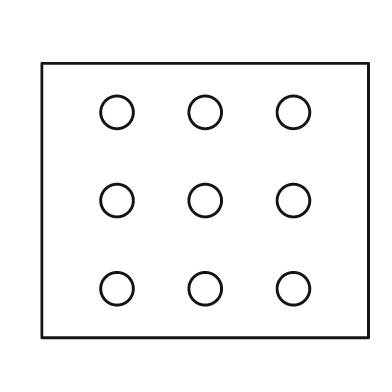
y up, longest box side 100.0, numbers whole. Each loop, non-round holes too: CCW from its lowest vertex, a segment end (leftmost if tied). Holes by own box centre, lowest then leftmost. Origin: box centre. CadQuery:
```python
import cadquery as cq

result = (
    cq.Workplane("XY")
    .moveTo(-50.0, -42.0)
    .lineTo(50.0, -42.0)
    .lineTo(50.0, 42.0)
    .lineTo(-50.0, 42.0)
    .close()
    .moveTo(-27.0, -27.0)
    .circle(5.0)
    .moveTo(0.0, -27.0)
    .circle(5.0)
    .moveTo(27.0, -27.0)
    .circle(5.0)
    .moveTo(-27.0, 0.0)
    .circle(5.0)
    .moveTo(0.0, 0.0)
    .circle(5.0)
    .moveTo(27.0, 0.0)
    .circle(5.0)
    .moveTo(-27.0, 27.0)
    .circle(5.0)
    .moveTo(0.0, 27.0)
    .circle(5.0)
    .moveTo(27.0, 27.0)
    .circle(5.0)
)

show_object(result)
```